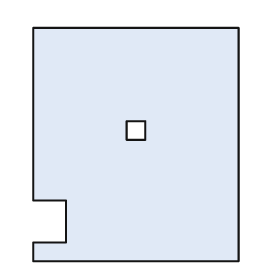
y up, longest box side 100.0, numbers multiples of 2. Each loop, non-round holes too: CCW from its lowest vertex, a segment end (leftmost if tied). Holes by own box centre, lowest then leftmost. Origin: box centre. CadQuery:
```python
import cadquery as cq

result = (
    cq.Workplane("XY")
    .moveTo(-44.0, -50.0)
    .lineTo(44.0, -50.0)
    .lineTo(44.0, 50.0)
    .lineTo(-44.0, 50.0)
    .lineTo(-44.0, -24.0)
    .lineTo(-30.0, -24.0)
    .lineTo(-30.0, -42.0)
    .lineTo(-44.0, -42.0)
    .close()
    .moveTo(-4.0, 2.0)
    .lineTo(4.0, 2.0)
    .lineTo(4.0, 10.0)
    .lineTo(-4.0, 10.0)
    .close()
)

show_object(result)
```